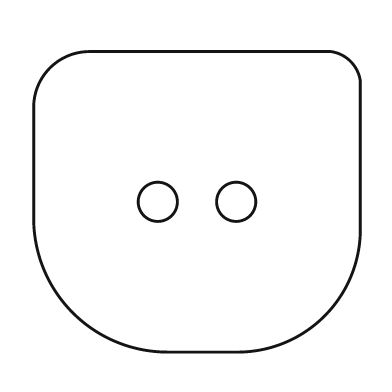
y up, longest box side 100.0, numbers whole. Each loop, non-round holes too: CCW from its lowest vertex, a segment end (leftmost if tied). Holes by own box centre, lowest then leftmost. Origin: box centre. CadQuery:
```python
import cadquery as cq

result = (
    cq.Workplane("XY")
    .moveTo(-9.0, -46.0)
    .lineTo(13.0, -46.0)
    .threePointArc((39.0, -35.0), (50.0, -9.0))
    .lineTo(50.0, 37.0)
    .threePointArc((47.0, 43.0), (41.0, 46.0))
    .lineTo(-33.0, 46.0)
    .threePointArc((-45.0, 41.0), (-50.0, 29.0))
    .lineTo(-50.0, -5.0)
    .threePointArc((-38.0, -34.0), (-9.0, -46.0))
    .close()
    .moveTo(-12.0, 0.0)
    .circle(6.0)
    .moveTo(12.0, 0.0)
    .circle(6.0)
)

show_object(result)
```